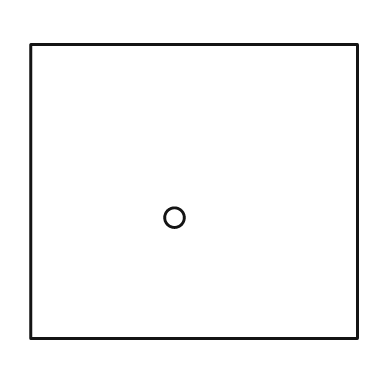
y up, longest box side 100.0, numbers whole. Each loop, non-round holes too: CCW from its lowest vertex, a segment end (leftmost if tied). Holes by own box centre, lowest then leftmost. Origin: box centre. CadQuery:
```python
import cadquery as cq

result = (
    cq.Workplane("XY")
    .moveTo(-50.0, -45.0)
    .lineTo(50.0, -45.0)
    .lineTo(50.0, 45.0)
    .lineTo(-50.0, 45.0)
    .close()
    .moveTo(-6.0, -8.0)
    .circle(3.0)
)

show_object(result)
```